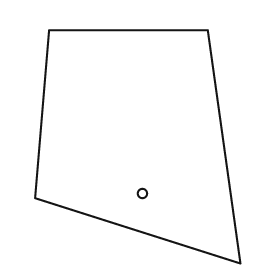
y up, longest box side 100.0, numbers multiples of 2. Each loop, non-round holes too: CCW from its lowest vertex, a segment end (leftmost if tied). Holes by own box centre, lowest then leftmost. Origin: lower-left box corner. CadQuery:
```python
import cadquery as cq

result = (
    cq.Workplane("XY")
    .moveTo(88.0, 0.0)
    .lineTo(74.0, 100.0)
    .lineTo(6.0, 100.0)
    .lineTo(0.0, 28.0)
    .close()
    .moveTo(46.0, 30.0)
    .circle(2.0)
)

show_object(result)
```